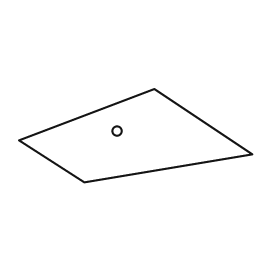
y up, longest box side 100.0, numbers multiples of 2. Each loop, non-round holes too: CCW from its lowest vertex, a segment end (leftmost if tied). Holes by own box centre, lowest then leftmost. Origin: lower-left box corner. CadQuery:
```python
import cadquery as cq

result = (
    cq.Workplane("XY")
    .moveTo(28.0, 0.0)
    .lineTo(100.0, 12.0)
    .lineTo(58.0, 40.0)
    .lineTo(0.0, 18.0)
    .close()
    .moveTo(42.0, 22.0)
    .circle(2.0)
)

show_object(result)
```